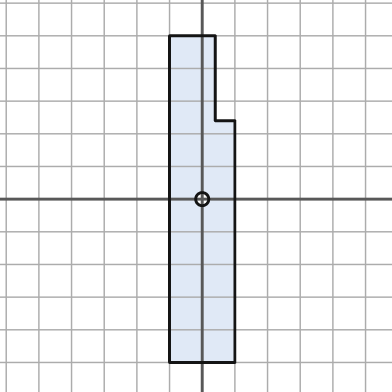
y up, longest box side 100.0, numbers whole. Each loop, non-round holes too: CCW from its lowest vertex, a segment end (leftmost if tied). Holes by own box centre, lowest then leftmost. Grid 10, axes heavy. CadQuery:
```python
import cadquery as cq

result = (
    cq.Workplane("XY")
    .moveTo(-10.0, -50.0)
    .lineTo(10.0, -50.0)
    .lineTo(10.0, 24.0)
    .lineTo(4.0, 24.0)
    .lineTo(4.0, 50.0)
    .lineTo(-10.0, 50.0)
    .close()
    .moveTo(0.0, 0.0)
    .circle(2.0)
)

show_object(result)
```